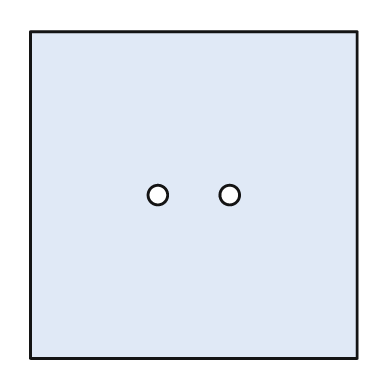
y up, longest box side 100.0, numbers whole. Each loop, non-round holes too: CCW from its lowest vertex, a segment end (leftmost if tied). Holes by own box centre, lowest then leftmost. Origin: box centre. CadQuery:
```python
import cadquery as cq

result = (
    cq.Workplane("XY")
    .moveTo(-50.0, -50.0)
    .lineTo(50.0, -50.0)
    .lineTo(50.0, 50.0)
    .lineTo(-50.0, 50.0)
    .close()
    .moveTo(-11.0, 0.0)
    .circle(3.0)
    .moveTo(11.0, 0.0)
    .circle(3.0)
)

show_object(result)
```